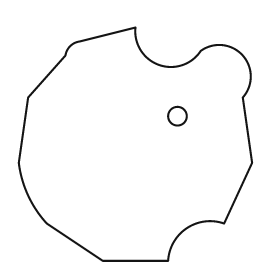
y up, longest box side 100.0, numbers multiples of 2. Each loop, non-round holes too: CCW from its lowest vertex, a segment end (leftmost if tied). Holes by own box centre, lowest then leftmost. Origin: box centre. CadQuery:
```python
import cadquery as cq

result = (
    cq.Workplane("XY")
    .moveTo(-14.0, -50.0)
    .lineTo(14.0, -50.0)
    .threePointArc((22.0, -36.0), (38.0, -34.0))
    .lineTo(50.0, -8.0)
    .lineTo(46.0, 20.0)
    .threePointArc((46.0, 38.0), (28.0, 40.0))
    .threePointArc((10.0, 34.0), (0.0, 50.0))
    .lineTo(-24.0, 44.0)
    .threePointArc((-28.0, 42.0), (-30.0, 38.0))
    .lineTo(-46.0, 20.0)
    .lineTo(-50.0, -8.0)
    .threePointArc((-46.0, -22.0), (-38.0, -34.0))
    .close()
    .moveTo(18.0, 12.0)
    .circle(4.0)
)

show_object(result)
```